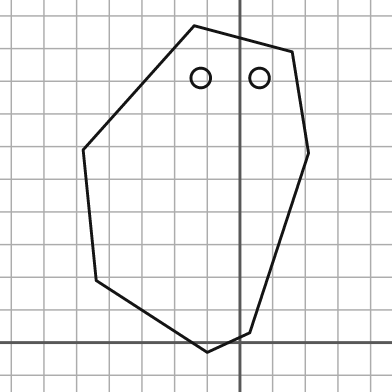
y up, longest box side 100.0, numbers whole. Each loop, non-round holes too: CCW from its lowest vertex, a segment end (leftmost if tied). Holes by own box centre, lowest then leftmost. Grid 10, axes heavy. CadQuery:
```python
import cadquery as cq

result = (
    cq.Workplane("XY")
    .moveTo(-10.0, -3.0)
    .lineTo(3.0, 3.0)
    .lineTo(21.0, 58.0)
    .lineTo(16.0, 89.0)
    .lineTo(-14.0, 97.0)
    .lineTo(-48.0, 59.0)
    .lineTo(-44.0, 19.0)
    .close()
    .moveTo(-12.0, 81.0)
    .circle(3.0)
    .moveTo(6.0, 81.0)
    .circle(3.0)
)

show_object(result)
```